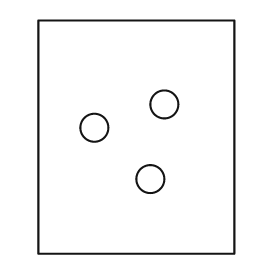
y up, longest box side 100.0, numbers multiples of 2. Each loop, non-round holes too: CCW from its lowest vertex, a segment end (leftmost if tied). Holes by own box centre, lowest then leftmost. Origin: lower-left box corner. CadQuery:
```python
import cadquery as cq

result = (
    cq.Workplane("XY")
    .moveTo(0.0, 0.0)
    .lineTo(84.0, 0.0)
    .lineTo(84.0, 100.0)
    .lineTo(0.0, 100.0)
    .close()
    .moveTo(48.0, 32.0)
    .circle(6.0)
    .moveTo(24.0, 54.0)
    .circle(6.0)
    .moveTo(54.0, 64.0)
    .circle(6.0)
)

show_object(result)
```